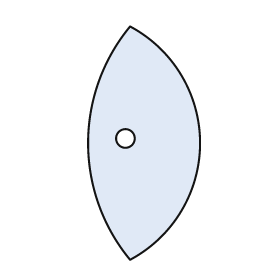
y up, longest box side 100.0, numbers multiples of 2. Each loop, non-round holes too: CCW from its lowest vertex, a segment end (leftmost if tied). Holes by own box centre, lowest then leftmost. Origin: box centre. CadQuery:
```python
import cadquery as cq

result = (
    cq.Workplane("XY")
    .moveTo(-6.0, -50.0)
    .threePointArc((24.0, 0.0), (-6.0, 50.0))
    .threePointArc((-24.0, 0.0), (-6.0, -50.0))
    .close()
    .moveTo(-8.0, 2.0)
    .circle(4.0)
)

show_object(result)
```